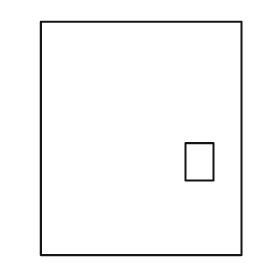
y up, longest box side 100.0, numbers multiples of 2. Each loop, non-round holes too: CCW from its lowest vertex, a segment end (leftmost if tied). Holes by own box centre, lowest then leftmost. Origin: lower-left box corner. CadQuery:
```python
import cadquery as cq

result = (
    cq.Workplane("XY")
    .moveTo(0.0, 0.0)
    .lineTo(86.0, 0.0)
    .lineTo(86.0, 100.0)
    .lineTo(0.0, 100.0)
    .close()
    .moveTo(62.0, 32.0)
    .lineTo(74.0, 32.0)
    .lineTo(74.0, 48.0)
    .lineTo(62.0, 48.0)
    .close()
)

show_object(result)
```